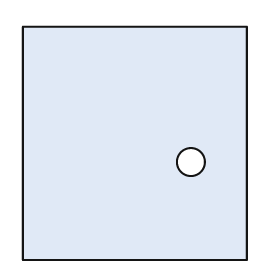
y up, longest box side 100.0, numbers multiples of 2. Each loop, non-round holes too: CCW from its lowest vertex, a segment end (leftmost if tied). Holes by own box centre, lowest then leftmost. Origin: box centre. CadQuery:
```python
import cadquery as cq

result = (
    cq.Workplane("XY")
    .moveTo(-48.0, -50.0)
    .lineTo(48.0, -50.0)
    .lineTo(48.0, 50.0)
    .lineTo(-48.0, 50.0)
    .close()
    .moveTo(24.0, -8.0)
    .circle(6.0)
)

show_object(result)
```